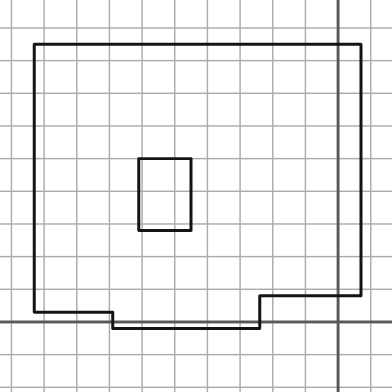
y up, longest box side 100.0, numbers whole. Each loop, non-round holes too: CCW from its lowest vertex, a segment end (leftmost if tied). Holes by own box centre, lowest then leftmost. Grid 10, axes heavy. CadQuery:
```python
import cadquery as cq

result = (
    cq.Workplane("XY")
    .moveTo(-69.0, -2.0)
    .lineTo(-24.0, -2.0)
    .lineTo(-24.0, 8.0)
    .lineTo(7.0, 8.0)
    .lineTo(7.0, 85.0)
    .lineTo(-93.0, 85.0)
    .lineTo(-93.0, 3.0)
    .lineTo(-69.0, 3.0)
    .close()
    .moveTo(-61.0, 28.0)
    .lineTo(-45.0, 28.0)
    .lineTo(-45.0, 50.0)
    .lineTo(-61.0, 50.0)
    .close()
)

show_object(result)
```